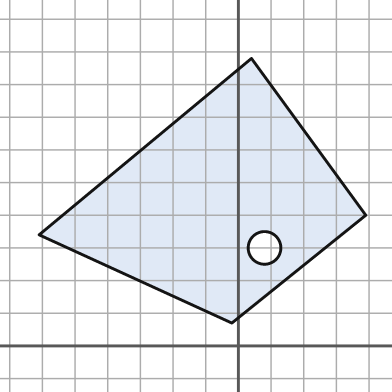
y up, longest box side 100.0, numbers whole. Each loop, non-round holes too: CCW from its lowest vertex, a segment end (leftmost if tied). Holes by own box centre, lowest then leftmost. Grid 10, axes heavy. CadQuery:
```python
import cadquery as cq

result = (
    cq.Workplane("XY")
    .moveTo(-2.0, 7.0)
    .lineTo(39.0, 40.0)
    .lineTo(4.0, 88.0)
    .lineTo(-61.0, 34.0)
    .close()
    .moveTo(8.0, 30.0)
    .circle(5.0)
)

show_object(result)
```